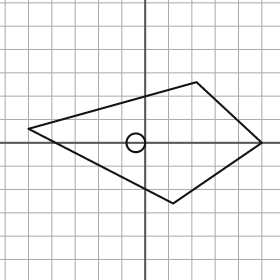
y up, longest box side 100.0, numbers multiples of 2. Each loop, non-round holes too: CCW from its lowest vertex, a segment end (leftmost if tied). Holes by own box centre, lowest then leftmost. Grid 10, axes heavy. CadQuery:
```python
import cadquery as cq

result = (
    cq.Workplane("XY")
    .moveTo(12.0, -26.0)
    .lineTo(50.0, 0.0)
    .lineTo(22.0, 26.0)
    .lineTo(-50.0, 6.0)
    .close()
    .moveTo(-4.0, 0.0)
    .circle(4.0)
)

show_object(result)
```